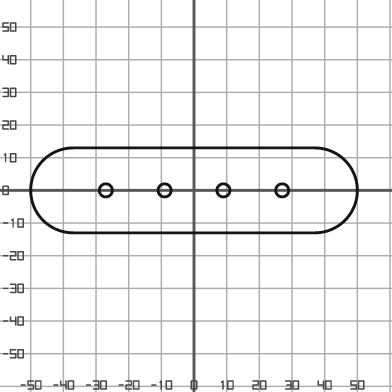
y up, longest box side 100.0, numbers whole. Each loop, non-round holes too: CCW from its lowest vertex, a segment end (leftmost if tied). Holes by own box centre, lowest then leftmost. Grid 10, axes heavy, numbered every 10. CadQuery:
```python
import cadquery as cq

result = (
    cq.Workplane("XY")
    .moveTo(-37.0, -13.0)
    .lineTo(37.0, -13.0)
    .threePointArc((50.0, 0.0), (37.0, 13.0))
    .lineTo(-37.0, 13.0)
    .threePointArc((-50.0, 0.0), (-37.0, -13.0))
    .close()
    .moveTo(-27.0, 0.0)
    .circle(2.0)
    .moveTo(-9.0, 0.0)
    .circle(2.0)
    .moveTo(9.0, 0.0)
    .circle(2.0)
    .moveTo(27.0, 0.0)
    .circle(2.0)
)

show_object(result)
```